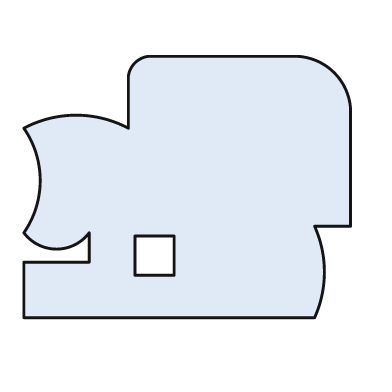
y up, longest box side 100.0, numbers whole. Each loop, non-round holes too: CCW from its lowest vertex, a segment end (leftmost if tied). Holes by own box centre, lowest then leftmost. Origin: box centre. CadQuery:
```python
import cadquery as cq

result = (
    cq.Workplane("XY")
    .moveTo(-50.0, -40.0)
    .lineTo(39.0, -40.0)
    .threePointArc((42.0, -26.0), (39.0, -12.0))
    .lineTo(50.0, -12.0)
    .lineTo(50.0, 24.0)
    .threePointArc((45.0, 35.0), (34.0, 40.0))
    .lineTo(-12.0, 40.0)
    .threePointArc((-16.0, 38.0), (-18.0, 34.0))
    .lineTo(-18.0, 18.0)
    .threePointArc((-34.0, 22.0), (-50.0, 18.0))
    .threePointArc((-45.0, 2.0), (-50.0, -14.0))
    .threePointArc((-40.0, -19.0), (-30.0, -14.0))
    .lineTo(-30.0, -23.0)
    .lineTo(-50.0, -23.0)
    .close()
    .moveTo(-16.0, -27.0)
    .lineTo(-4.0, -27.0)
    .lineTo(-4.0, -15.0)
    .lineTo(-16.0, -15.0)
    .close()
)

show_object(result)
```